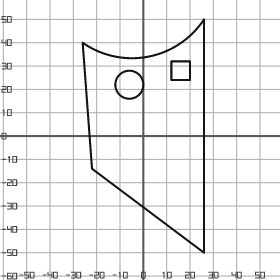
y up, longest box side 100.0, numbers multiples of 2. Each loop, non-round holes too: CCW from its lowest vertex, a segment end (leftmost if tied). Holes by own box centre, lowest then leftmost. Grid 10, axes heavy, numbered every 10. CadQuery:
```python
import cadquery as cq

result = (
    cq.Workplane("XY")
    .moveTo(26.0, -50.0)
    .lineTo(26.0, 50.0)
    .threePointArc((2.0, 34.0), (-26.0, 40.0))
    .lineTo(-22.0, -14.0)
    .close()
    .moveTo(-6.0, 22.0)
    .circle(6.0)
    .moveTo(12.0, 24.0)
    .lineTo(20.0, 24.0)
    .lineTo(20.0, 32.0)
    .lineTo(12.0, 32.0)
    .close()
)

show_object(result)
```